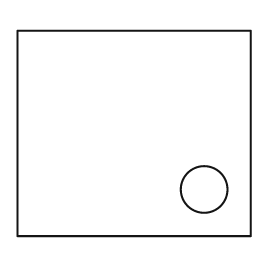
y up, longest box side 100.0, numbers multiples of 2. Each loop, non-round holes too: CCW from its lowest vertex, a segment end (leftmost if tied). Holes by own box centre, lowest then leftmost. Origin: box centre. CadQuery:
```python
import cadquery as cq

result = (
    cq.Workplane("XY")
    .moveTo(-50.0, -44.0)
    .lineTo(50.0, -44.0)
    .lineTo(50.0, 44.0)
    .lineTo(-50.0, 44.0)
    .close()
    .moveTo(30.0, -24.0)
    .circle(10.0)
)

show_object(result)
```